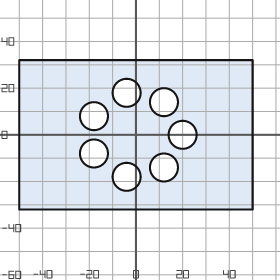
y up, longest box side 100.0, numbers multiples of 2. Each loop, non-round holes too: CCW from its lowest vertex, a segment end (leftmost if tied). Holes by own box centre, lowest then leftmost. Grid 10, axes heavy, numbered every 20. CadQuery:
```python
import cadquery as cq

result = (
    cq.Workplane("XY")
    .moveTo(-50.0, -32.0)
    .lineTo(50.0, -32.0)
    .lineTo(50.0, 32.0)
    .lineTo(-50.0, 32.0)
    .close()
    .moveTo(-4.0, -18.0)
    .circle(6.0)
    .moveTo(12.0, -14.0)
    .circle(6.0)
    .moveTo(-18.0, -8.0)
    .circle(6.0)
    .moveTo(20.0, 0.0)
    .circle(6.0)
    .moveTo(-18.0, 8.0)
    .circle(6.0)
    .moveTo(12.0, 14.0)
    .circle(6.0)
    .moveTo(-4.0, 18.0)
    .circle(6.0)
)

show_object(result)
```